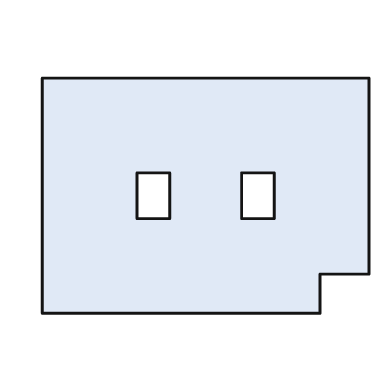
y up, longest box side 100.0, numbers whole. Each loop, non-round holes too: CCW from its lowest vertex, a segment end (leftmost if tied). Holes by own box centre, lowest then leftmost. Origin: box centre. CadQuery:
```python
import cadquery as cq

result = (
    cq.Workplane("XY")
    .moveTo(-50.0, -36.0)
    .lineTo(35.0, -36.0)
    .lineTo(35.0, -24.0)
    .lineTo(50.0, -24.0)
    .lineTo(50.0, 36.0)
    .lineTo(-50.0, 36.0)
    .close()
    .moveTo(-21.0, -7.0)
    .lineTo(-11.0, -7.0)
    .lineTo(-11.0, 7.0)
    .lineTo(-21.0, 7.0)
    .close()
    .moveTo(11.0, -7.0)
    .lineTo(21.0, -7.0)
    .lineTo(21.0, 7.0)
    .lineTo(11.0, 7.0)
    .close()
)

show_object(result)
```